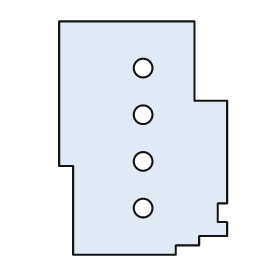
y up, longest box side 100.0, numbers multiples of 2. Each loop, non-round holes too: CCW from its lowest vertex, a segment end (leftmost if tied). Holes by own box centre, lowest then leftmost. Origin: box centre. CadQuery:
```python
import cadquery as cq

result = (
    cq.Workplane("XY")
    .moveTo(-30.0, -50.0)
    .lineTo(14.0, -50.0)
    .lineTo(14.0, -46.0)
    .lineTo(24.0, -46.0)
    .lineTo(24.0, -42.0)
    .lineTo(36.0, -42.0)
    .lineTo(36.0, -36.0)
    .lineTo(32.0, -36.0)
    .lineTo(32.0, -28.0)
    .lineTo(36.0, -28.0)
    .lineTo(36.0, 16.0)
    .lineTo(22.0, 16.0)
    .lineTo(22.0, 50.0)
    .lineTo(-36.0, 50.0)
    .lineTo(-36.0, -12.0)
    .lineTo(-30.0, -12.0)
    .close()
    .moveTo(0.0, -30.0)
    .circle(4.0)
    .moveTo(0.0, -10.0)
    .circle(4.0)
    .moveTo(0.0, 10.0)
    .circle(4.0)
    .moveTo(0.0, 30.0)
    .circle(4.0)
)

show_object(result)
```